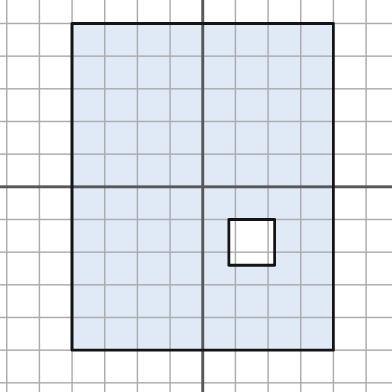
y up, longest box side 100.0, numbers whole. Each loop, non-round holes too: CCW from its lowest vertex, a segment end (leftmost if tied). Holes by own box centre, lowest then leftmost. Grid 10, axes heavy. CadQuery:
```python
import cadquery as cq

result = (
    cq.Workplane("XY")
    .moveTo(-40.0, -50.0)
    .lineTo(40.0, -50.0)
    .lineTo(40.0, 50.0)
    .lineTo(-40.0, 50.0)
    .close()
    .moveTo(8.0, -24.0)
    .lineTo(22.0, -24.0)
    .lineTo(22.0, -10.0)
    .lineTo(8.0, -10.0)
    .close()
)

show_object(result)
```